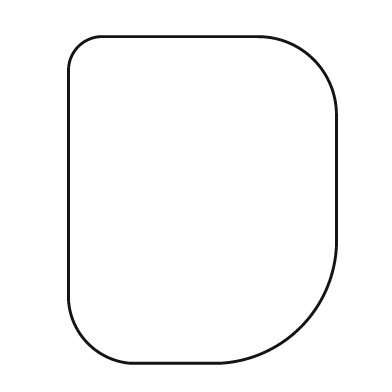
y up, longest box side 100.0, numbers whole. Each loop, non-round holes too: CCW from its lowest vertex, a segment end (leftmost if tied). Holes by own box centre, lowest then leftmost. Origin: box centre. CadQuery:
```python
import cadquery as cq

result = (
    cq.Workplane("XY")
    .moveTo(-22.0, -50.0)
    .lineTo(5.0, -50.0)
    .threePointArc((30.0, -39.0), (41.0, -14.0))
    .lineTo(41.0, 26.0)
    .threePointArc((34.0, 43.0), (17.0, 50.0))
    .lineTo(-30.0, 50.0)
    .threePointArc((-38.0, 47.0), (-41.0, 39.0))
    .lineTo(-41.0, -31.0)
    .threePointArc((-35.0, -44.0), (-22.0, -50.0))
    .close()
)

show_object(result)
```